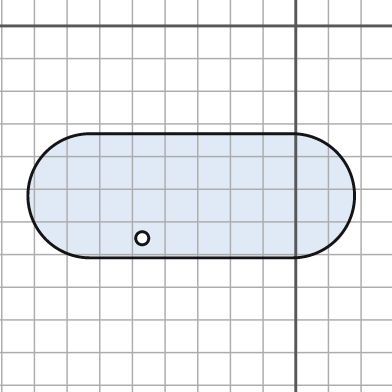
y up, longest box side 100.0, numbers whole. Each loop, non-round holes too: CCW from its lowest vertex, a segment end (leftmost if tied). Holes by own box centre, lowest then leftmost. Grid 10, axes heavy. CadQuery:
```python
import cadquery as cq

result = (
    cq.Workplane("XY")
    .moveTo(-63.0, -71.0)
    .lineTo(-1.0, -71.0)
    .threePointArc((18.0, -52.0), (-1.0, -33.0))
    .lineTo(-63.0, -33.0)
    .threePointArc((-82.0, -52.0), (-63.0, -71.0))
    .close()
    .moveTo(-47.0, -65.0)
    .circle(2.0)
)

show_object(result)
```